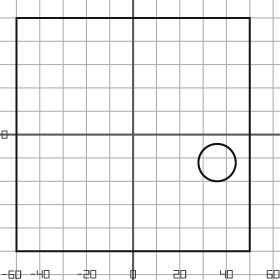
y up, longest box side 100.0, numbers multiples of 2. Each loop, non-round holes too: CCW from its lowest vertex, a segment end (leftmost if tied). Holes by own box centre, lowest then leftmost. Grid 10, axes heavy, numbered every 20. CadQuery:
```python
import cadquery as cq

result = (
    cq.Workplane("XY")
    .moveTo(-50.0, -50.0)
    .lineTo(50.0, -50.0)
    .lineTo(50.0, 50.0)
    .lineTo(-50.0, 50.0)
    .close()
    .moveTo(36.0, -12.0)
    .circle(8.0)
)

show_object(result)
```